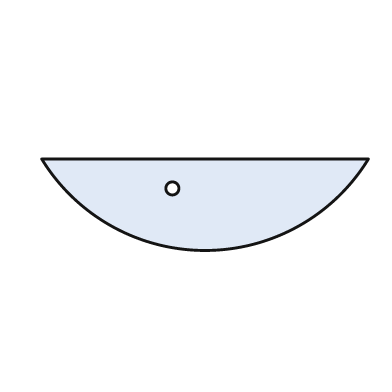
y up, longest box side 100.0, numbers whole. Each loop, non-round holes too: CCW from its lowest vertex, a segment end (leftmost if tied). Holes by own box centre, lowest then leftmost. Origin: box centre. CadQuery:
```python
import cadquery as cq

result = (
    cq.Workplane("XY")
    .moveTo(-50.0, 14.0)
    .threePointArc((0.0, -14.0), (50.0, 14.0))
    .close()
    .moveTo(-10.0, 5.0)
    .circle(2.0)
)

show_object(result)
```